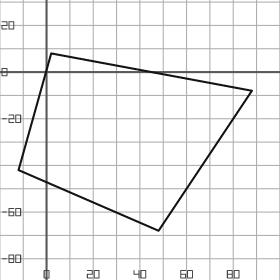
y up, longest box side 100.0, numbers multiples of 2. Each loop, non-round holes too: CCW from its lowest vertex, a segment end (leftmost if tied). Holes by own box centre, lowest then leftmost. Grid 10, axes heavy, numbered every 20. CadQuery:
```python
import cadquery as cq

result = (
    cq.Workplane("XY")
    .moveTo(48.0, -68.0)
    .lineTo(88.0, -8.0)
    .lineTo(2.0, 8.0)
    .lineTo(-12.0, -42.0)
    .close()
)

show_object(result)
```